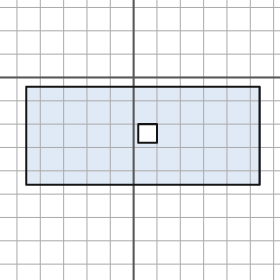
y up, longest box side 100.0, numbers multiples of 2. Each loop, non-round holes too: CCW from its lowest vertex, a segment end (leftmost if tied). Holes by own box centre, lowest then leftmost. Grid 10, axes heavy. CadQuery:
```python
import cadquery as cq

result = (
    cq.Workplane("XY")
    .moveTo(-46.0, -46.0)
    .lineTo(54.0, -46.0)
    .lineTo(54.0, -4.0)
    .lineTo(-46.0, -4.0)
    .close()
    .moveTo(2.0, -28.0)
    .lineTo(10.0, -28.0)
    .lineTo(10.0, -20.0)
    .lineTo(2.0, -20.0)
    .close()
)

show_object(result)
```